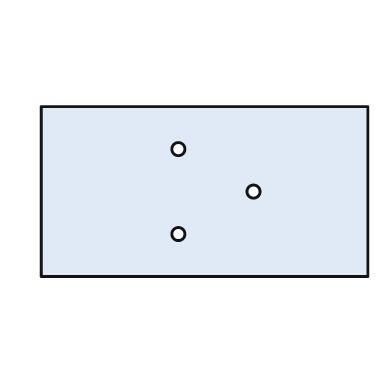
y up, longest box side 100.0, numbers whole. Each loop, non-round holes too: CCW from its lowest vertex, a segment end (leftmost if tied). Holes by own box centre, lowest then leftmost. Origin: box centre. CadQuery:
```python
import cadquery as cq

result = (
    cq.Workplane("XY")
    .moveTo(-50.0, -26.0)
    .lineTo(50.0, -26.0)
    .lineTo(50.0, 26.0)
    .lineTo(-50.0, 26.0)
    .close()
    .moveTo(-8.0, -13.0)
    .circle(2.0)
    .moveTo(15.0, 0.0)
    .circle(2.0)
    .moveTo(-8.0, 13.0)
    .circle(2.0)
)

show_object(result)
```